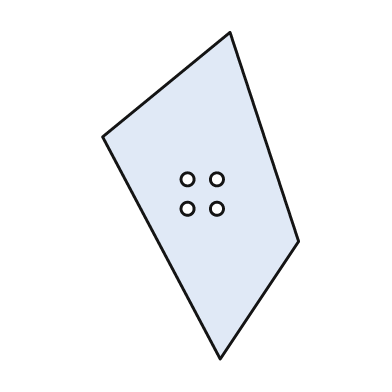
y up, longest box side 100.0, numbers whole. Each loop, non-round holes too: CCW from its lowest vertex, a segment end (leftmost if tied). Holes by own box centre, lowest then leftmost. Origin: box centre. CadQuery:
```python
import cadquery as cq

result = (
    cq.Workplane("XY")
    .moveTo(6.0, -50.0)
    .lineTo(30.0, -14.0)
    .lineTo(9.0, 50.0)
    .lineTo(-30.0, 18.0)
    .close()
    .moveTo(-4.0, -4.0)
    .circle(2.0)
    .moveTo(5.0, -4.0)
    .circle(2.0)
    .moveTo(-4.0, 5.0)
    .circle(2.0)
    .moveTo(5.0, 5.0)
    .circle(2.0)
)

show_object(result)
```